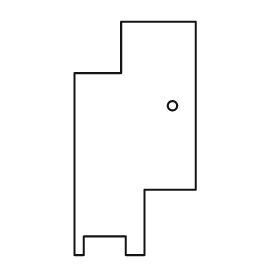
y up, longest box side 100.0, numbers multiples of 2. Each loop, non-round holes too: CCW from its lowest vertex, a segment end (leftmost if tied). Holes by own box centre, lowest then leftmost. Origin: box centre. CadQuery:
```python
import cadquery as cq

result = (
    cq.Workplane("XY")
    .moveTo(-26.0, -50.0)
    .lineTo(-22.0, -50.0)
    .lineTo(-22.0, -42.0)
    .lineTo(-4.0, -42.0)
    .lineTo(-4.0, -50.0)
    .lineTo(4.0, -50.0)
    .lineTo(4.0, -22.0)
    .lineTo(26.0, -22.0)
    .lineTo(26.0, 50.0)
    .lineTo(-6.0, 50.0)
    .lineTo(-6.0, 28.0)
    .lineTo(-26.0, 28.0)
    .close()
    .moveTo(16.0, 14.0)
    .circle(2.0)
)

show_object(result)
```